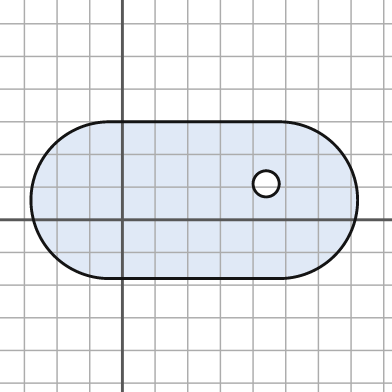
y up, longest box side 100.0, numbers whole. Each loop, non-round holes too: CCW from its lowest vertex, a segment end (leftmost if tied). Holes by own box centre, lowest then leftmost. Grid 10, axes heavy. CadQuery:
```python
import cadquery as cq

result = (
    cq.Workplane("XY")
    .moveTo(-4.0, -18.0)
    .lineTo(48.0, -18.0)
    .threePointArc((72.0, 6.0), (48.0, 30.0))
    .lineTo(-4.0, 30.0)
    .threePointArc((-28.0, 6.0), (-4.0, -18.0))
    .close()
    .moveTo(44.0, 11.0)
    .circle(4.0)
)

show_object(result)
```